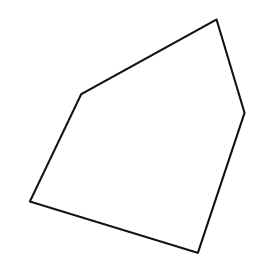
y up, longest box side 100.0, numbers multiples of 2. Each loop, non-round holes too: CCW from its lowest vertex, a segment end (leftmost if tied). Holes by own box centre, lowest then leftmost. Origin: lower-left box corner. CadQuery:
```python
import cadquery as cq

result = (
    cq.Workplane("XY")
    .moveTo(72.0, 0.0)
    .lineTo(92.0, 60.0)
    .lineTo(80.0, 100.0)
    .lineTo(22.0, 68.0)
    .lineTo(0.0, 22.0)
    .close()
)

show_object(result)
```